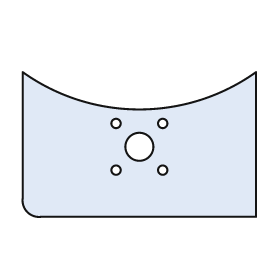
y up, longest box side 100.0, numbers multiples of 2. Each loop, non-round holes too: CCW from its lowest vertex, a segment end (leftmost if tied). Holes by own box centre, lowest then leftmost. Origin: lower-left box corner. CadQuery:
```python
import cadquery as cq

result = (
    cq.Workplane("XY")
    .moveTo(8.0, 0.0)
    .lineTo(100.0, 0.0)
    .lineTo(100.0, 62.0)
    .threePointArc((50.0, 46.0), (0.0, 62.0))
    .lineTo(0.0, 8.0)
    .threePointArc((2.0, 2.0), (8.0, 0.0))
    .close()
    .moveTo(40.0, 20.0)
    .circle(2.0)
    .moveTo(60.0, 20.0)
    .circle(2.0)
    .moveTo(50.0, 30.0)
    .circle(6.0)
    .moveTo(40.0, 40.0)
    .circle(2.0)
    .moveTo(60.0, 40.0)
    .circle(2.0)
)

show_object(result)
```